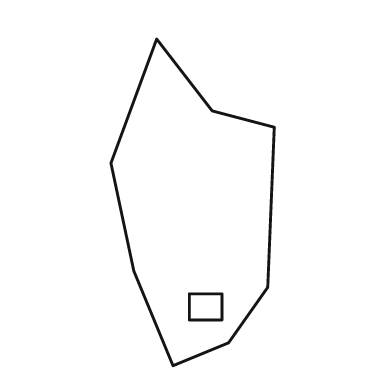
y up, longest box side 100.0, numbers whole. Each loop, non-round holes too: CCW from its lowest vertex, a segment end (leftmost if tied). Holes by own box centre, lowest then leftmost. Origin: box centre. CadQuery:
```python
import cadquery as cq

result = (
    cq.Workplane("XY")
    .moveTo(-6.0, -50.0)
    .lineTo(11.0, -43.0)
    .lineTo(23.0, -26.0)
    .lineTo(25.0, 23.0)
    .lineTo(6.0, 28.0)
    .lineTo(-11.0, 50.0)
    .lineTo(-25.0, 12.0)
    .lineTo(-18.0, -21.0)
    .close()
    .moveTo(-1.0, -36.0)
    .lineTo(9.0, -36.0)
    .lineTo(9.0, -28.0)
    .lineTo(-1.0, -28.0)
    .close()
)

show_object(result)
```